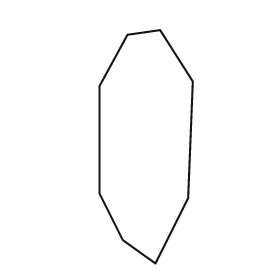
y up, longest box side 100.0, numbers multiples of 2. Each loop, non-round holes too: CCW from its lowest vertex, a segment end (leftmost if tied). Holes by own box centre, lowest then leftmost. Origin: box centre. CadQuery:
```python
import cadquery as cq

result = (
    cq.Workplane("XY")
    .moveTo(4.0, -50.0)
    .lineTo(18.0, -22.0)
    .lineTo(20.0, 28.0)
    .lineTo(6.0, 50.0)
    .lineTo(-8.0, 48.0)
    .lineTo(-20.0, 26.0)
    .lineTo(-20.0, -20.0)
    .lineTo(-10.0, -40.0)
    .close()
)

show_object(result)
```